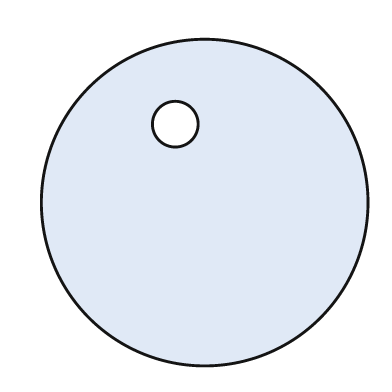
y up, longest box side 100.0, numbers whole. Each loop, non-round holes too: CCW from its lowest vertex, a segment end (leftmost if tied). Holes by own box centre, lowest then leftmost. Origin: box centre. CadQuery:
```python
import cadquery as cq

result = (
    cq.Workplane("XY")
    .moveTo(0.0, 0.0)
    .circle(50.0)
    .moveTo(-9.0, 24.0)
    .circle(7.0)
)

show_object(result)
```